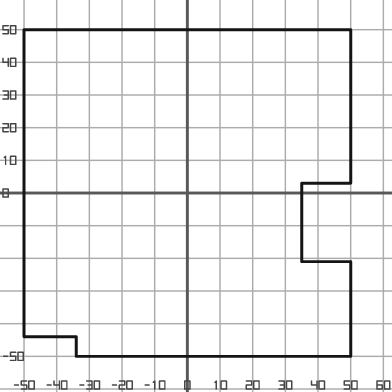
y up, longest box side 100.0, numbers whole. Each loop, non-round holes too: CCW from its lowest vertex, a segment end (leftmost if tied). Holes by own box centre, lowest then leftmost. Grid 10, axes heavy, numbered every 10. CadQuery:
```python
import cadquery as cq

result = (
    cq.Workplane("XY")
    .moveTo(-34.0, -50.0)
    .lineTo(50.0, -50.0)
    .lineTo(50.0, -21.0)
    .lineTo(35.0, -21.0)
    .lineTo(35.0, 3.0)
    .lineTo(50.0, 3.0)
    .lineTo(50.0, 50.0)
    .lineTo(-50.0, 50.0)
    .lineTo(-50.0, -44.0)
    .lineTo(-34.0, -44.0)
    .close()
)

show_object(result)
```